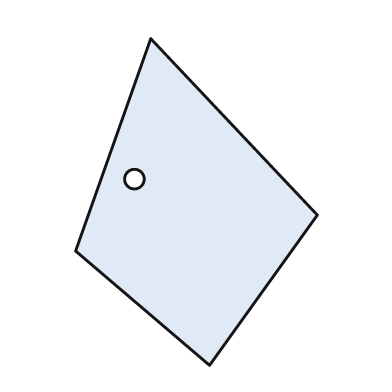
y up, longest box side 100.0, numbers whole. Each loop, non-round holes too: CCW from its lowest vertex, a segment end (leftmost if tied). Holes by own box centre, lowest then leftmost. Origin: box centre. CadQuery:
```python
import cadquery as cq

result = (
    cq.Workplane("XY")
    .moveTo(4.0, -50.0)
    .lineTo(37.0, -4.0)
    .lineTo(-14.0, 50.0)
    .lineTo(-37.0, -15.0)
    .close()
    .moveTo(-19.0, 7.0)
    .circle(3.0)
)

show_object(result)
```